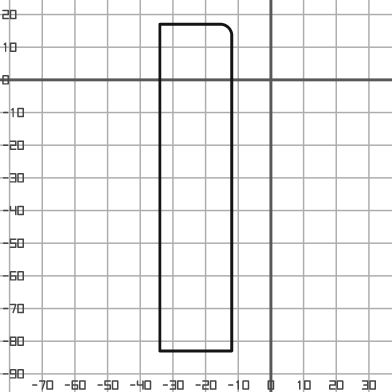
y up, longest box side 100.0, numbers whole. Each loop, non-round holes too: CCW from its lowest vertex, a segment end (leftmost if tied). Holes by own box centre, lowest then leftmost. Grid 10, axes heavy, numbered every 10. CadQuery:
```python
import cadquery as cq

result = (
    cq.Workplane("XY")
    .moveTo(-34.0, -83.0)
    .lineTo(-12.0, -83.0)
    .lineTo(-12.0, 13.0)
    .threePointArc((-13.0, 16.0), (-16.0, 17.0))
    .lineTo(-34.0, 17.0)
    .close()
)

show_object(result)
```